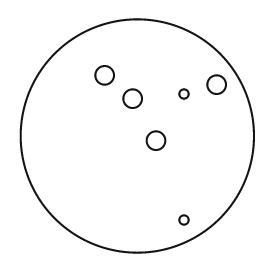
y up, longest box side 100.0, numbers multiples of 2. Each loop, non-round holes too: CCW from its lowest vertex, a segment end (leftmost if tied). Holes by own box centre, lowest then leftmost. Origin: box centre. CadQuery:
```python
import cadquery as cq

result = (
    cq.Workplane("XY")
    .moveTo(0.0, 0.0)
    .circle(50.0)
    .moveTo(20.0, -36.0)
    .circle(2.0)
    .moveTo(8.0, -2.0)
    .circle(4.0)
    .moveTo(-2.0, 16.0)
    .circle(4.0)
    .moveTo(20.0, 18.0)
    .circle(2.0)
    .moveTo(34.0, 22.0)
    .circle(4.0)
    .moveTo(-14.0, 26.0)
    .circle(4.0)
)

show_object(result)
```